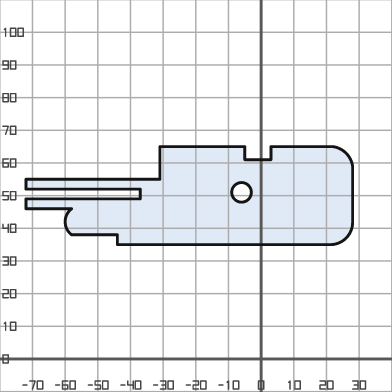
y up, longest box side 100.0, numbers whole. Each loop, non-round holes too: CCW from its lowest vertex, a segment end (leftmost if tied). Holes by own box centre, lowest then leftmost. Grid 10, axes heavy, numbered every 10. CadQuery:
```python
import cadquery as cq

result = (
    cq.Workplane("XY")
    .moveTo(-44.0, 35.0)
    .lineTo(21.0, 35.0)
    .threePointArc((26.0, 37.0), (28.0, 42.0))
    .lineTo(28.0, 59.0)
    .threePointArc((26.0, 63.0), (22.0, 65.0))
    .lineTo(3.0, 65.0)
    .lineTo(3.0, 61.0)
    .lineTo(-5.0, 61.0)
    .lineTo(-5.0, 65.0)
    .lineTo(-31.0, 65.0)
    .lineTo(-31.0, 55.0)
    .lineTo(-72.0, 55.0)
    .lineTo(-72.0, 52.0)
    .lineTo(-37.0, 52.0)
    .lineTo(-37.0, 49.0)
    .lineTo(-72.0, 49.0)
    .lineTo(-72.0, 46.0)
    .lineTo(-58.0, 46.0)
    .threePointArc((-60.0, 42.0), (-58.0, 38.0))
    .lineTo(-44.0, 38.0)
    .close()
    .moveTo(-6.0, 51.0)
    .circle(3.0)
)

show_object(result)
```